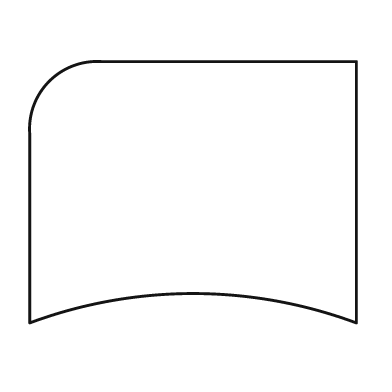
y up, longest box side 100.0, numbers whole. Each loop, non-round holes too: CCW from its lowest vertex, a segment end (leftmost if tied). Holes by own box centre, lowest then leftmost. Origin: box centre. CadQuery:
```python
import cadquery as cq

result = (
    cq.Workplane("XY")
    .moveTo(-50.0, -40.0)
    .threePointArc((0.0, -31.0), (50.0, -40.0))
    .lineTo(50.0, 40.0)
    .lineTo(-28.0, 40.0)
    .threePointArc((-44.0, 34.0), (-50.0, 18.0))
    .close()
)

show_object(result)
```